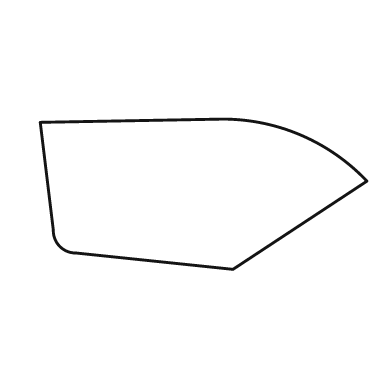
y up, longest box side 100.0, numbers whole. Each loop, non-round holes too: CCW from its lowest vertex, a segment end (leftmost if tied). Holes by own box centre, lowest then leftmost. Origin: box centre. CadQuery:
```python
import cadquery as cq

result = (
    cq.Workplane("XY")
    .moveTo(9.0, -23.0)
    .lineTo(50.0, 4.0)
    .threePointArc((30.0, 18.0), (6.0, 23.0))
    .lineTo(-50.0, 22.0)
    .lineTo(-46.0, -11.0)
    .threePointArc((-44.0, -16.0), (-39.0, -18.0))
    .close()
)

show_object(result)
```